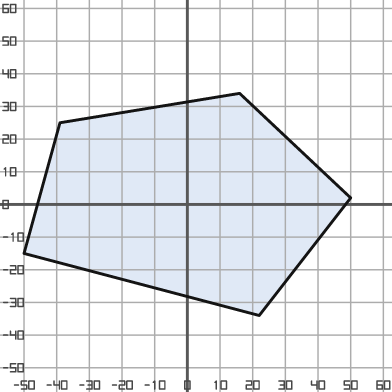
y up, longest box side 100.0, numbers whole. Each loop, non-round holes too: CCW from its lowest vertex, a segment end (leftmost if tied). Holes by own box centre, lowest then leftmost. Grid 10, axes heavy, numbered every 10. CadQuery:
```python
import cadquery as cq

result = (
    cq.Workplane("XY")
    .moveTo(22.0, -34.0)
    .lineTo(50.0, 2.0)
    .lineTo(16.0, 34.0)
    .lineTo(-39.0, 25.0)
    .lineTo(-50.0, -15.0)
    .close()
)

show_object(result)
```